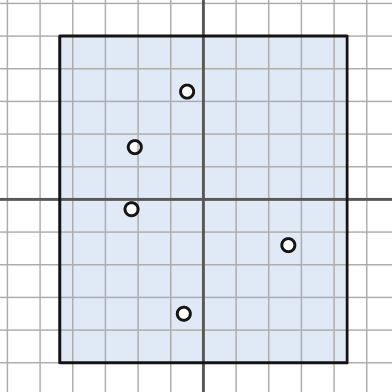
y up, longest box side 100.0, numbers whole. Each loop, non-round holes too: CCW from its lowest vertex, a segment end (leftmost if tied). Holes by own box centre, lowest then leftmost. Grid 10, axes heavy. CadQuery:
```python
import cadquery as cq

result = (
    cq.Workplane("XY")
    .moveTo(-44.0, -50.0)
    .lineTo(44.0, -50.0)
    .lineTo(44.0, 50.0)
    .lineTo(-44.0, 50.0)
    .close()
    .moveTo(-6.0, -35.0)
    .circle(2.0)
    .moveTo(26.0, -14.0)
    .circle(2.0)
    .moveTo(-22.0, -3.0)
    .circle(2.0)
    .moveTo(-21.0, 16.0)
    .circle(2.0)
    .moveTo(-5.0, 33.0)
    .circle(2.0)
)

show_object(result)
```